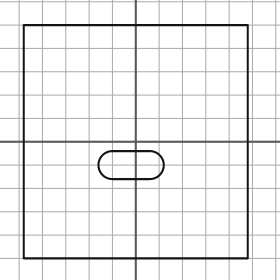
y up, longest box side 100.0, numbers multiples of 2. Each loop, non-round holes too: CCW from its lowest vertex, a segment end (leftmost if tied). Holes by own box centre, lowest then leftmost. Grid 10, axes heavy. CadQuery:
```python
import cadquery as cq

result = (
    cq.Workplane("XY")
    .moveTo(-48.0, -50.0)
    .lineTo(48.0, -50.0)
    .lineTo(48.0, 50.0)
    .lineTo(-48.0, 50.0)
    .close()
    .moveTo(-10.0, -16.0)
    .lineTo(6.0, -16.0)
    .threePointArc((12.0, -10.0), (6.0, -4.0))
    .lineTo(-10.0, -4.0)
    .threePointArc((-16.0, -10.0), (-10.0, -16.0))
    .close()
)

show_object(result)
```